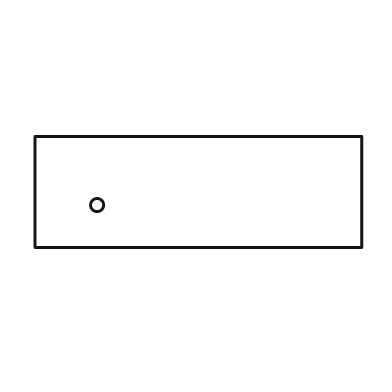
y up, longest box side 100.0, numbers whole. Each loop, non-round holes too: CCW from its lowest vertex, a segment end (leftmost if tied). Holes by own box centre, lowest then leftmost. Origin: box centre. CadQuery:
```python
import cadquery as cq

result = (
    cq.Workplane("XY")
    .moveTo(-50.0, -17.0)
    .lineTo(50.0, -17.0)
    .lineTo(50.0, 17.0)
    .lineTo(-50.0, 17.0)
    .close()
    .moveTo(-31.0, -4.0)
    .circle(2.0)
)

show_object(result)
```